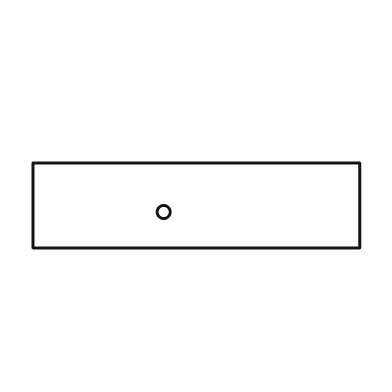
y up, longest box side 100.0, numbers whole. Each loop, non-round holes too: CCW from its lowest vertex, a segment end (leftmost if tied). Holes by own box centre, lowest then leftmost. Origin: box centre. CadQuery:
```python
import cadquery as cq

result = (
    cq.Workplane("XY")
    .moveTo(-50.0, -13.0)
    .lineTo(50.0, -13.0)
    .lineTo(50.0, 13.0)
    .lineTo(-50.0, 13.0)
    .close()
    .moveTo(-10.0, -2.0)
    .circle(2.0)
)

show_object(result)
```